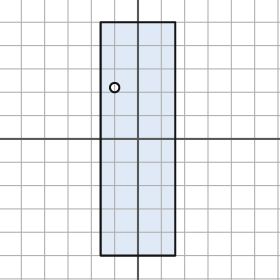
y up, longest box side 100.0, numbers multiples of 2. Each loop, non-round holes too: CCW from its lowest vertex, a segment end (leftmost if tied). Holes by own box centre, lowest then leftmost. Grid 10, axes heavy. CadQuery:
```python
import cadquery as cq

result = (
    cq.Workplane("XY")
    .moveTo(-16.0, -50.0)
    .lineTo(16.0, -50.0)
    .lineTo(16.0, 50.0)
    .lineTo(-16.0, 50.0)
    .close()
    .moveTo(-10.0, 22.0)
    .circle(2.0)
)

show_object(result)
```